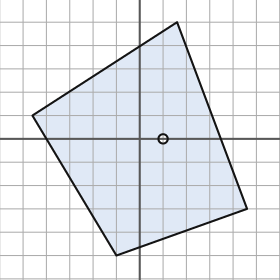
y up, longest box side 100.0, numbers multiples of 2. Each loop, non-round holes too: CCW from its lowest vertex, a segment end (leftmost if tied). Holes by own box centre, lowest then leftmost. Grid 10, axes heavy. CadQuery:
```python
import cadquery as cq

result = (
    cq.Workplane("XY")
    .moveTo(-10.0, -50.0)
    .lineTo(46.0, -30.0)
    .lineTo(16.0, 50.0)
    .lineTo(-46.0, 10.0)
    .close()
    .moveTo(10.0, 0.0)
    .circle(2.0)
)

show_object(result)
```